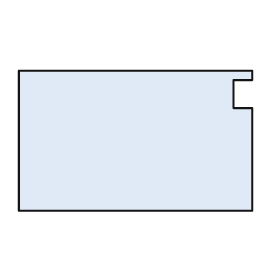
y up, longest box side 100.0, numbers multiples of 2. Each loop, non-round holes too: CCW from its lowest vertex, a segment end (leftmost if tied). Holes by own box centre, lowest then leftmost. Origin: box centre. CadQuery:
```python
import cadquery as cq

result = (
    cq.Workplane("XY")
    .moveTo(-50.0, -30.0)
    .lineTo(50.0, -30.0)
    .lineTo(50.0, 14.0)
    .lineTo(42.0, 14.0)
    .lineTo(42.0, 26.0)
    .lineTo(50.0, 26.0)
    .lineTo(50.0, 30.0)
    .lineTo(-50.0, 30.0)
    .close()
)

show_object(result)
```